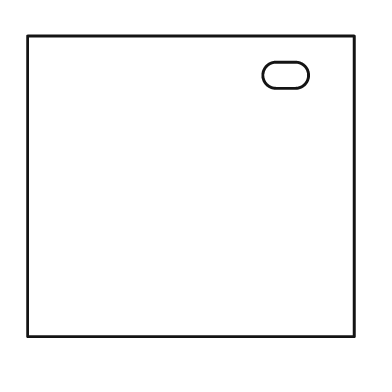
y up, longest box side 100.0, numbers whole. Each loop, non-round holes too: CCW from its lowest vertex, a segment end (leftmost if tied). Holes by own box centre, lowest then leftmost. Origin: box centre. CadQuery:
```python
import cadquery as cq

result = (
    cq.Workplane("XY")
    .moveTo(-50.0, -46.0)
    .lineTo(50.0, -46.0)
    .lineTo(50.0, 46.0)
    .lineTo(-50.0, 46.0)
    .close()
    .moveTo(26.0, 30.0)
    .lineTo(32.0, 30.0)
    .threePointArc((36.0, 34.0), (32.0, 38.0))
    .lineTo(26.0, 38.0)
    .threePointArc((22.0, 34.0), (26.0, 30.0))
    .close()
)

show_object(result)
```